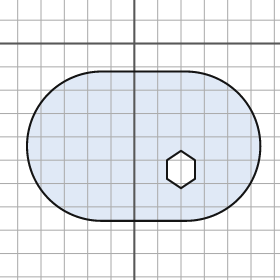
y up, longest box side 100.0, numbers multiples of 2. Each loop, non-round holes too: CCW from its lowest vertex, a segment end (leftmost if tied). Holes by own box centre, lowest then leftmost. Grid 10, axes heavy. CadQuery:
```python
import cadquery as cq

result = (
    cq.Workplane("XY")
    .moveTo(-14.0, -76.0)
    .lineTo(22.0, -76.0)
    .threePointArc((54.0, -44.0), (22.0, -12.0))
    .lineTo(-14.0, -12.0)
    .threePointArc((-46.0, -44.0), (-14.0, -76.0))
    .close()
    .moveTo(20.0, -62.0)
    .lineTo(26.0, -58.0)
    .lineTo(26.0, -50.0)
    .lineTo(20.0, -46.0)
    .lineTo(14.0, -50.0)
    .lineTo(14.0, -58.0)
    .close()
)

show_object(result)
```